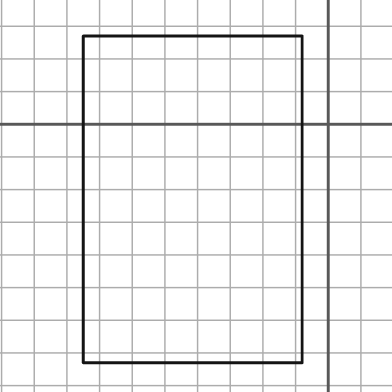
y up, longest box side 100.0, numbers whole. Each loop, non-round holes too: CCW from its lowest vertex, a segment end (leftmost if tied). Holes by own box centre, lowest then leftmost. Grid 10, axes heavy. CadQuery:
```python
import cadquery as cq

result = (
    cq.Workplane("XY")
    .moveTo(-75.0, -73.0)
    .lineTo(-8.0, -73.0)
    .lineTo(-8.0, 27.0)
    .lineTo(-75.0, 27.0)
    .close()
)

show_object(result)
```